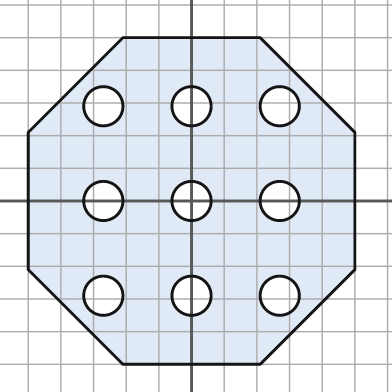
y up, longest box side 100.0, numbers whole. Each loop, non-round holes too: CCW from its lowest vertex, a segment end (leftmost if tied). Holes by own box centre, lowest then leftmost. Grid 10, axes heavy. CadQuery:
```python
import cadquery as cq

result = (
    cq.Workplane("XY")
    .moveTo(-21.0, -50.0)
    .lineTo(21.0, -50.0)
    .lineTo(50.0, -21.0)
    .lineTo(50.0, 21.0)
    .lineTo(21.0, 50.0)
    .lineTo(-21.0, 50.0)
    .lineTo(-50.0, 21.0)
    .lineTo(-50.0, -21.0)
    .close()
    .moveTo(-27.0, -29.0)
    .circle(6.0)
    .moveTo(0.0, -29.0)
    .circle(6.0)
    .moveTo(27.0, -29.0)
    .circle(6.0)
    .moveTo(-27.0, 0.0)
    .circle(6.0)
    .moveTo(0.0, 0.0)
    .circle(6.0)
    .moveTo(27.0, 0.0)
    .circle(6.0)
    .moveTo(-27.0, 29.0)
    .circle(6.0)
    .moveTo(0.0, 29.0)
    .circle(6.0)
    .moveTo(27.0, 29.0)
    .circle(6.0)
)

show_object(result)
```